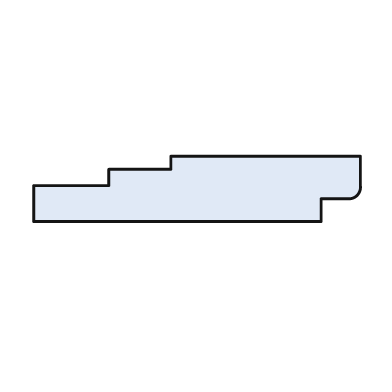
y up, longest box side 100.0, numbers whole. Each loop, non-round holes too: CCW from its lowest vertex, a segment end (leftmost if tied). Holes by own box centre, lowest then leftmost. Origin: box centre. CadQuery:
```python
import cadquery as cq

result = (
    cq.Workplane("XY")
    .moveTo(-50.0, -10.0)
    .lineTo(38.0, -10.0)
    .lineTo(38.0, -3.0)
    .lineTo(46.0, -3.0)
    .threePointArc((49.0, -2.0), (50.0, 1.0))
    .lineTo(50.0, 10.0)
    .lineTo(-8.0, 10.0)
    .lineTo(-8.0, 6.0)
    .lineTo(-27.0, 6.0)
    .lineTo(-27.0, 1.0)
    .lineTo(-50.0, 1.0)
    .close()
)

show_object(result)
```